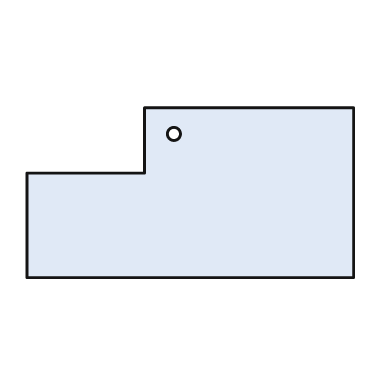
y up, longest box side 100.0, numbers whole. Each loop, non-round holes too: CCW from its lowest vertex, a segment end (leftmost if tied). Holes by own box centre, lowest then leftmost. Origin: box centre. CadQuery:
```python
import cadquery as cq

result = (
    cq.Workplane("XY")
    .moveTo(-50.0, -26.0)
    .lineTo(50.0, -26.0)
    .lineTo(50.0, 26.0)
    .lineTo(-14.0, 26.0)
    .lineTo(-14.0, 6.0)
    .lineTo(-50.0, 6.0)
    .close()
    .moveTo(-5.0, 18.0)
    .circle(2.0)
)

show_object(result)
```